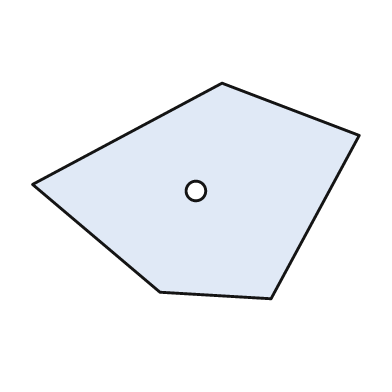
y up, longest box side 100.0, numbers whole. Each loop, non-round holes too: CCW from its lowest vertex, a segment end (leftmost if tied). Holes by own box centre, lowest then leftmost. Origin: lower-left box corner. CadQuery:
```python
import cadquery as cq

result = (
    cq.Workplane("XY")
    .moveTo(73.0, 0.0)
    .lineTo(100.0, 50.0)
    .lineTo(58.0, 66.0)
    .lineTo(0.0, 35.0)
    .lineTo(39.0, 2.0)
    .close()
    .moveTo(50.0, 33.0)
    .circle(3.0)
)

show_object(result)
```